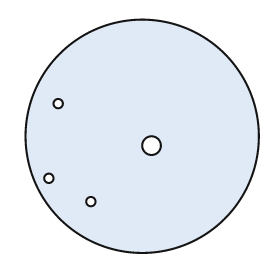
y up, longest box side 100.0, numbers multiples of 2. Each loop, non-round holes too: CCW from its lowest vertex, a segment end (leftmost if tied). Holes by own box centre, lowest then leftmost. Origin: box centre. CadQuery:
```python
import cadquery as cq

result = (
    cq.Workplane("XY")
    .moveTo(0.0, 0.0)
    .circle(50.0)
    .moveTo(-22.0, -28.0)
    .circle(2.0)
    .moveTo(-40.0, -18.0)
    .circle(2.0)
    .moveTo(4.0, -4.0)
    .circle(4.0)
    .moveTo(-36.0, 14.0)
    .circle(2.0)
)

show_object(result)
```